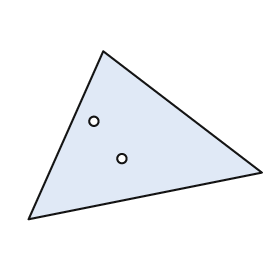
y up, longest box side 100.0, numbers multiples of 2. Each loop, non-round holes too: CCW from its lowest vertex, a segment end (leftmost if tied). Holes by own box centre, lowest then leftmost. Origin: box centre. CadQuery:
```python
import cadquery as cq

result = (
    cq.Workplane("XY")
    .moveTo(-50.0, -36.0)
    .lineTo(50.0, -16.0)
    .lineTo(-18.0, 36.0)
    .close()
    .moveTo(-10.0, -10.0)
    .circle(2.0)
    .moveTo(-22.0, 6.0)
    .circle(2.0)
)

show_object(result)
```